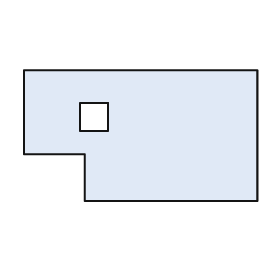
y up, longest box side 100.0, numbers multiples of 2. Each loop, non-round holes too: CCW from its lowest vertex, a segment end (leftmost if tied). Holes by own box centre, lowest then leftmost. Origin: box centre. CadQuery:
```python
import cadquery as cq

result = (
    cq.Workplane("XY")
    .moveTo(-24.0, -28.0)
    .lineTo(50.0, -28.0)
    .lineTo(50.0, 28.0)
    .lineTo(-50.0, 28.0)
    .lineTo(-50.0, -8.0)
    .lineTo(-24.0, -8.0)
    .close()
    .moveTo(-26.0, 2.0)
    .lineTo(-14.0, 2.0)
    .lineTo(-14.0, 14.0)
    .lineTo(-26.0, 14.0)
    .close()
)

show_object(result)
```